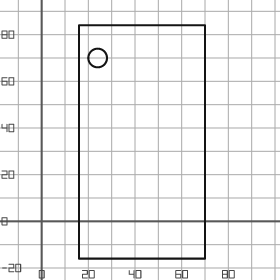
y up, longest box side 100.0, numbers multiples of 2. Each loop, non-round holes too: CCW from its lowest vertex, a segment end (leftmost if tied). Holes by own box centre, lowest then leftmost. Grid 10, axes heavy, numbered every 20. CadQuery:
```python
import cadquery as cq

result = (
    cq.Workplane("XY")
    .moveTo(16.0, -16.0)
    .lineTo(70.0, -16.0)
    .lineTo(70.0, 84.0)
    .lineTo(16.0, 84.0)
    .close()
    .moveTo(24.0, 70.0)
    .circle(4.0)
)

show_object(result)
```